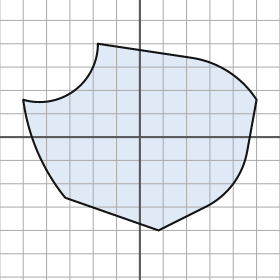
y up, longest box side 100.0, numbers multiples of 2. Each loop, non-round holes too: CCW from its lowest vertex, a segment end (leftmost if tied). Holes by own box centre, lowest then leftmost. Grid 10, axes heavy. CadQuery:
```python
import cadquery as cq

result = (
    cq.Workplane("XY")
    .moveTo(8.0, -40.0)
    .lineTo(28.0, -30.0)
    .threePointArc((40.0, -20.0), (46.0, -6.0))
    .lineTo(50.0, 16.0)
    .threePointArc((38.0, 28.0), (22.0, 34.0))
    .lineTo(-18.0, 40.0)
    .threePointArc((-28.0, 20.0), (-50.0, 16.0))
    .threePointArc((-44.0, -6.0), (-32.0, -26.0))
    .close()
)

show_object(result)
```